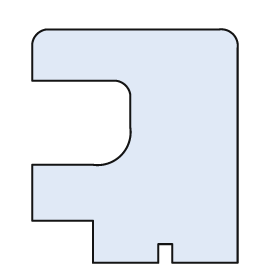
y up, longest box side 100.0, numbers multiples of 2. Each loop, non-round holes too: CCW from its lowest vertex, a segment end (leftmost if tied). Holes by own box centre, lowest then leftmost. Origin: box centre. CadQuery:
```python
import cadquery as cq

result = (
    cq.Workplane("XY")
    .moveTo(-18.0, -50.0)
    .lineTo(10.0, -50.0)
    .lineTo(10.0, -42.0)
    .lineTo(16.0, -42.0)
    .lineTo(16.0, -50.0)
    .lineTo(44.0, -50.0)
    .lineTo(44.0, 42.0)
    .threePointArc((42.0, 48.0), (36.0, 50.0))
    .lineTo(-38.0, 50.0)
    .threePointArc((-42.0, 48.0), (-44.0, 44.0))
    .lineTo(-44.0, 28.0)
    .lineTo(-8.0, 28.0)
    .threePointArc((-4.0, 26.0), (-2.0, 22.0))
    .lineTo(-2.0, 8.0)
    .threePointArc((-6.0, -4.0), (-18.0, -8.0))
    .lineTo(-44.0, -8.0)
    .lineTo(-44.0, -32.0)
    .lineTo(-18.0, -32.0)
    .close()
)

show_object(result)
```